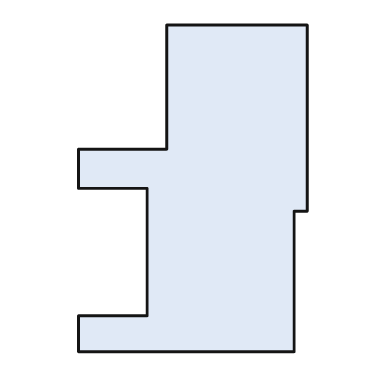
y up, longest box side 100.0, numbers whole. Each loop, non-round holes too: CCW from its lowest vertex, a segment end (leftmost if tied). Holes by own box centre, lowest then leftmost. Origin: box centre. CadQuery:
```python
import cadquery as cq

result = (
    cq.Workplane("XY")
    .moveTo(-35.0, -50.0)
    .lineTo(31.0, -50.0)
    .lineTo(31.0, -7.0)
    .lineTo(35.0, -7.0)
    .lineTo(35.0, 50.0)
    .lineTo(-8.0, 50.0)
    .lineTo(-8.0, 12.0)
    .lineTo(-35.0, 12.0)
    .lineTo(-35.0, 0.0)
    .lineTo(-14.0, 0.0)
    .lineTo(-14.0, -39.0)
    .lineTo(-35.0, -39.0)
    .close()
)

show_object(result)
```